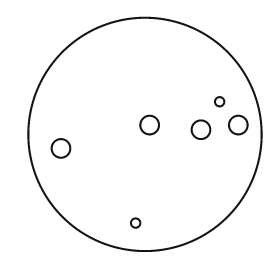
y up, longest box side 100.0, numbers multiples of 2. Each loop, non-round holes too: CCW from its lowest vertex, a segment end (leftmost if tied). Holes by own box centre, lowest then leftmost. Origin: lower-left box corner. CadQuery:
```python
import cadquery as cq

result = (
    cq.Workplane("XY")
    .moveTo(50.0, 50.0)
    .circle(50.0)
    .moveTo(46.0, 12.0)
    .circle(2.0)
    .moveTo(14.0, 44.0)
    .circle(4.0)
    .moveTo(74.0, 52.0)
    .circle(4.0)
    .moveTo(52.0, 54.0)
    .circle(4.0)
    .moveTo(90.0, 54.0)
    .circle(4.0)
    .moveTo(82.0, 64.0)
    .circle(2.0)
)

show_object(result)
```